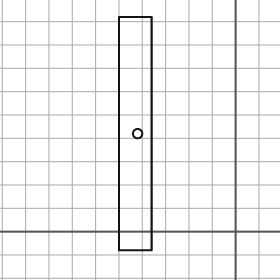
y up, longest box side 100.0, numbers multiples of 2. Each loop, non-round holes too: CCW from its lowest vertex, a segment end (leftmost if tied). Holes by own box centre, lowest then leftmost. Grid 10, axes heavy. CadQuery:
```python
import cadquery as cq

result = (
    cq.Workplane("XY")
    .moveTo(-50.0, -8.0)
    .lineTo(-36.0, -8.0)
    .lineTo(-36.0, 92.0)
    .lineTo(-50.0, 92.0)
    .close()
    .moveTo(-42.0, 42.0)
    .circle(2.0)
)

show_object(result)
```